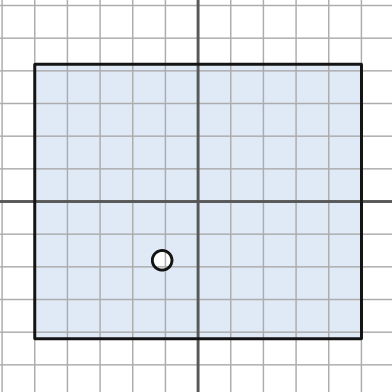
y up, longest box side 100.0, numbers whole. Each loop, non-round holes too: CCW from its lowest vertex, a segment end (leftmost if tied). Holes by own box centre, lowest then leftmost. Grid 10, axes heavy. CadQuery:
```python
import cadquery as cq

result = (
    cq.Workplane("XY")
    .moveTo(-50.0, -42.0)
    .lineTo(50.0, -42.0)
    .lineTo(50.0, 42.0)
    .lineTo(-50.0, 42.0)
    .close()
    .moveTo(-11.0, -18.0)
    .circle(3.0)
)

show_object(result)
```